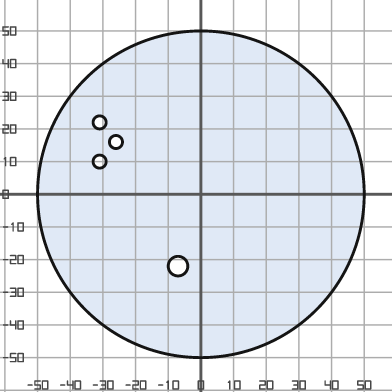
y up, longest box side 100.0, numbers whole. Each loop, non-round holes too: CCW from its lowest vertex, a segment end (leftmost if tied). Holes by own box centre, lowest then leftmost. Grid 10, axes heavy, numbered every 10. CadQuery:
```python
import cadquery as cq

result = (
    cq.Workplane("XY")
    .moveTo(0.0, 0.0)
    .circle(50.0)
    .moveTo(-7.0, -22.0)
    .circle(3.0)
    .moveTo(-31.0, 10.0)
    .circle(2.0)
    .moveTo(-26.0, 16.0)
    .circle(2.0)
    .moveTo(-31.0, 22.0)
    .circle(2.0)
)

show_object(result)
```